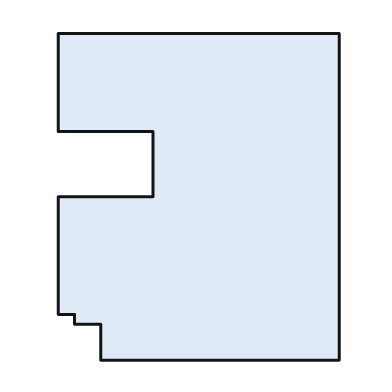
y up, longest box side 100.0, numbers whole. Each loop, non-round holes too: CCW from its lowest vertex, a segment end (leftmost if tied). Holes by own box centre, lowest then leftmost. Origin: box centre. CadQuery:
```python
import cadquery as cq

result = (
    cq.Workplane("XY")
    .moveTo(-30.0, -50.0)
    .lineTo(43.0, -50.0)
    .lineTo(43.0, 50.0)
    .lineTo(-43.0, 50.0)
    .lineTo(-43.0, 20.0)
    .lineTo(-14.0, 20.0)
    .lineTo(-14.0, 0.0)
    .lineTo(-43.0, 0.0)
    .lineTo(-43.0, -36.0)
    .lineTo(-38.0, -36.0)
    .lineTo(-38.0, -39.0)
    .lineTo(-30.0, -39.0)
    .close()
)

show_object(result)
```